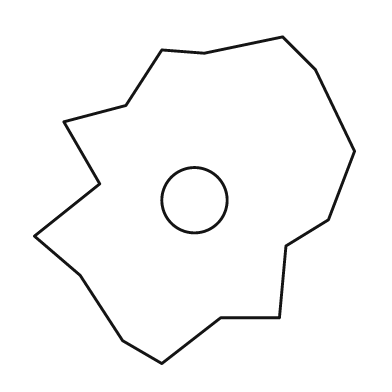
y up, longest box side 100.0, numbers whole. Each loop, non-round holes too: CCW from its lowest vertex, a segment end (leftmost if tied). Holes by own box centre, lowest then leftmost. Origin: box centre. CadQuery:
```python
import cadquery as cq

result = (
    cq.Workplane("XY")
    .moveTo(-10.0, -50.0)
    .lineTo(8.0, -36.0)
    .lineTo(26.0, -36.0)
    .lineTo(28.0, -14.0)
    .lineTo(41.0, -6.0)
    .lineTo(49.0, 15.0)
    .lineTo(37.0, 40.0)
    .lineTo(27.0, 50.0)
    .lineTo(3.0, 45.0)
    .lineTo(-10.0, 46.0)
    .lineTo(-21.0, 29.0)
    .lineTo(-40.0, 24.0)
    .lineTo(-29.0, 5.0)
    .lineTo(-49.0, -11.0)
    .lineTo(-35.0, -23.0)
    .lineTo(-22.0, -43.0)
    .close()
    .moveTo(0.0, 0.0)
    .circle(10.0)
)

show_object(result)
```